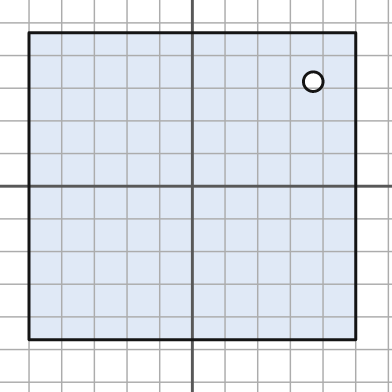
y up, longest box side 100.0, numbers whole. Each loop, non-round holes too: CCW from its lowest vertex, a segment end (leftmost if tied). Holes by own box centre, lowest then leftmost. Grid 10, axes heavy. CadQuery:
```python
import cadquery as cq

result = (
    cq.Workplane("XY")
    .moveTo(-50.0, -47.0)
    .lineTo(50.0, -47.0)
    .lineTo(50.0, 47.0)
    .lineTo(-50.0, 47.0)
    .close()
    .moveTo(37.0, 32.0)
    .circle(3.0)
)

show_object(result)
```